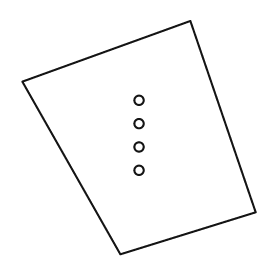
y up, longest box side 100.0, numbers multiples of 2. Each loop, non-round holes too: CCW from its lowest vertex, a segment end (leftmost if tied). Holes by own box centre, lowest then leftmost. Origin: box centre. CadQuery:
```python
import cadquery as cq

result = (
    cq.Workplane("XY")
    .moveTo(-8.0, -50.0)
    .lineTo(50.0, -32.0)
    .lineTo(22.0, 50.0)
    .lineTo(-50.0, 24.0)
    .close()
    .moveTo(0.0, -14.0)
    .circle(2.0)
    .moveTo(0.0, -4.0)
    .circle(2.0)
    .moveTo(0.0, 6.0)
    .circle(2.0)
    .moveTo(0.0, 16.0)
    .circle(2.0)
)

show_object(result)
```